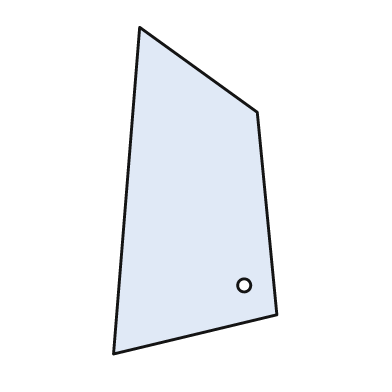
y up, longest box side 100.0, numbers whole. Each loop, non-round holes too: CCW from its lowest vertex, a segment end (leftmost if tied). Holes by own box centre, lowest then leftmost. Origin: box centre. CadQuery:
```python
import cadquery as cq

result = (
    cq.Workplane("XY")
    .moveTo(-25.0, -50.0)
    .lineTo(25.0, -38.0)
    .lineTo(19.0, 24.0)
    .lineTo(-17.0, 50.0)
    .close()
    .moveTo(15.0, -29.0)
    .circle(2.0)
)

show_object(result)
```